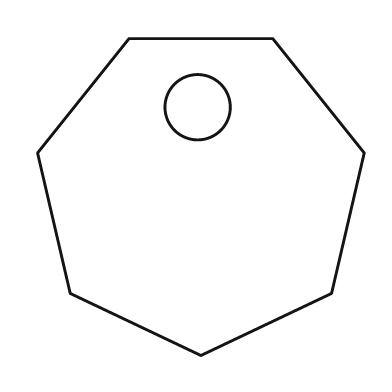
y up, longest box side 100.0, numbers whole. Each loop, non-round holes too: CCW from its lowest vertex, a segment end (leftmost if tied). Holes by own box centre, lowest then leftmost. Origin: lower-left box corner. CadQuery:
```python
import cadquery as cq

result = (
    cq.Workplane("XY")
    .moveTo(50.0, 0.0)
    .lineTo(90.0, 19.0)
    .lineTo(100.0, 62.0)
    .lineTo(72.0, 97.0)
    .lineTo(28.0, 97.0)
    .lineTo(0.0, 62.0)
    .lineTo(10.0, 19.0)
    .close()
    .moveTo(49.0, 76.0)
    .circle(10.0)
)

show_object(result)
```